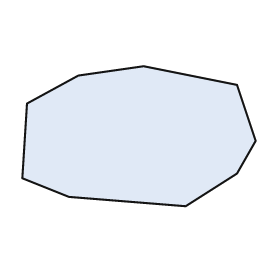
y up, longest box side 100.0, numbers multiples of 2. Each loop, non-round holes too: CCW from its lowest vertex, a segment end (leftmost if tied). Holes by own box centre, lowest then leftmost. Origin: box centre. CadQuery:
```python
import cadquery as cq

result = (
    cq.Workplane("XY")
    .moveTo(20.0, -30.0)
    .lineTo(42.0, -16.0)
    .lineTo(50.0, -2.0)
    .lineTo(42.0, 22.0)
    .lineTo(2.0, 30.0)
    .lineTo(-26.0, 26.0)
    .lineTo(-48.0, 14.0)
    .lineTo(-50.0, -18.0)
    .lineTo(-30.0, -26.0)
    .close()
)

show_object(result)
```